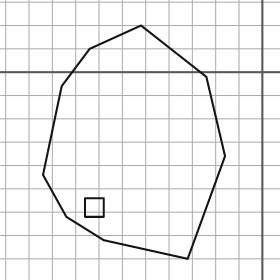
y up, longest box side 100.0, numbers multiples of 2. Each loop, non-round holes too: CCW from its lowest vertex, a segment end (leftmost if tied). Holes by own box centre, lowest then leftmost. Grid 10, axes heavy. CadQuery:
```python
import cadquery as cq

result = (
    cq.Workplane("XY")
    .moveTo(-32.0, -80.0)
    .lineTo(-16.0, -36.0)
    .lineTo(-24.0, -2.0)
    .lineTo(-52.0, 20.0)
    .lineTo(-74.0, 10.0)
    .lineTo(-86.0, -6.0)
    .lineTo(-94.0, -44.0)
    .lineTo(-84.0, -62.0)
    .lineTo(-68.0, -72.0)
    .close()
    .moveTo(-76.0, -62.0)
    .lineTo(-68.0, -62.0)
    .lineTo(-68.0, -54.0)
    .lineTo(-76.0, -54.0)
    .close()
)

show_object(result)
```